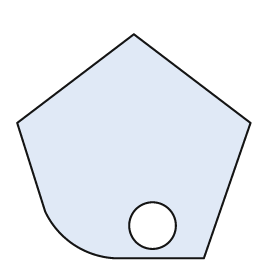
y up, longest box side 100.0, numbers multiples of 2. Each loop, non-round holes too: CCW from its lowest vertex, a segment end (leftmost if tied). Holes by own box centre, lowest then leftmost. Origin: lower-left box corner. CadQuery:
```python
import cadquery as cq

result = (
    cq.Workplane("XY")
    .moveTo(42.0, 0.0)
    .lineTo(80.0, 0.0)
    .lineTo(100.0, 58.0)
    .lineTo(50.0, 96.0)
    .lineTo(0.0, 58.0)
    .lineTo(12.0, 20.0)
    .threePointArc((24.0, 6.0), (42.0, 0.0))
    .close()
    .moveTo(58.0, 14.0)
    .circle(10.0)
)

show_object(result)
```